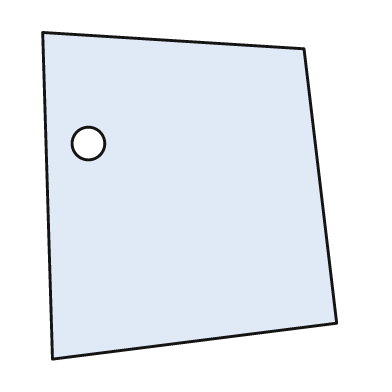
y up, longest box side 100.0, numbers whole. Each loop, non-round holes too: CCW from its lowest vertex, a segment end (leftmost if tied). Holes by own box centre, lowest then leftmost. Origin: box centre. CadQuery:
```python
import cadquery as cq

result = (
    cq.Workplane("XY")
    .moveTo(-42.0, -50.0)
    .lineTo(45.0, -39.0)
    .lineTo(35.0, 45.0)
    .lineTo(-45.0, 50.0)
    .close()
    .moveTo(-31.0, 16.0)
    .circle(5.0)
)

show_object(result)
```